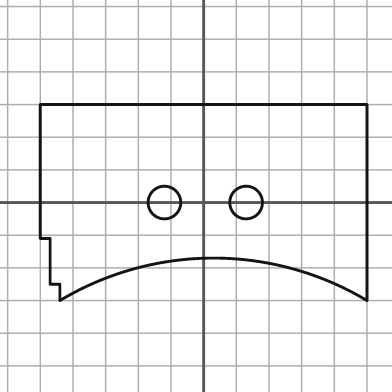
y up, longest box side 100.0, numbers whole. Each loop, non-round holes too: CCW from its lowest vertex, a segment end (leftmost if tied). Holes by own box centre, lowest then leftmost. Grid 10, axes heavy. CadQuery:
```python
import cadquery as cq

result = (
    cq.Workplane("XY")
    .moveTo(-44.0, -30.0)
    .threePointArc((3.0, -17.0), (50.0, -30.0))
    .lineTo(50.0, 30.0)
    .lineTo(-50.0, 30.0)
    .lineTo(-50.0, -11.0)
    .lineTo(-47.0, -11.0)
    .lineTo(-47.0, -25.0)
    .lineTo(-44.0, -25.0)
    .close()
    .moveTo(-12.0, 0.0)
    .circle(5.0)
    .moveTo(13.0, 0.0)
    .circle(5.0)
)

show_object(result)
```